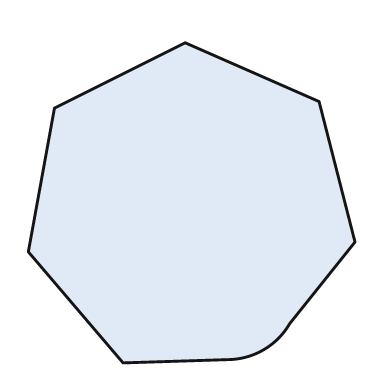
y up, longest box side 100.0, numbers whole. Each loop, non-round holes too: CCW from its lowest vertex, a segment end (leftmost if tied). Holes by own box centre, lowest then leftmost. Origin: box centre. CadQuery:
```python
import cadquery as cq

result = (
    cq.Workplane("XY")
    .moveTo(-21.0, -49.0)
    .lineTo(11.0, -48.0)
    .threePointArc((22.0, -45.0), (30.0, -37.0))
    .lineTo(50.0, -12.0)
    .lineTo(39.0, 31.0)
    .lineTo(-2.0, 49.0)
    .lineTo(-42.0, 29.0)
    .lineTo(-50.0, -15.0)
    .close()
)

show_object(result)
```